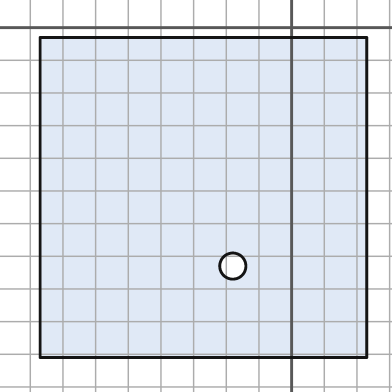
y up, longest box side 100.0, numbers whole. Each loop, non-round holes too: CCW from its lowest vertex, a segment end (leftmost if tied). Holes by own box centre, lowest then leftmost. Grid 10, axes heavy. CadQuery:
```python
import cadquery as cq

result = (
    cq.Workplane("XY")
    .moveTo(-77.0, -101.0)
    .lineTo(23.0, -101.0)
    .lineTo(23.0, -3.0)
    .lineTo(-77.0, -3.0)
    .close()
    .moveTo(-18.0, -73.0)
    .circle(4.0)
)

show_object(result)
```